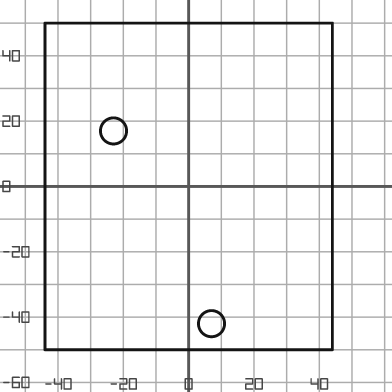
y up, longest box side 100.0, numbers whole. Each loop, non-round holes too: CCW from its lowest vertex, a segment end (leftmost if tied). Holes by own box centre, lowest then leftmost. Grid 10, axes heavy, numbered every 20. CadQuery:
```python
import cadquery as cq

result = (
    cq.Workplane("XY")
    .moveTo(-44.0, -50.0)
    .lineTo(44.0, -50.0)
    .lineTo(44.0, 50.0)
    .lineTo(-44.0, 50.0)
    .close()
    .moveTo(7.0, -42.0)
    .circle(4.0)
    .moveTo(-23.0, 17.0)
    .circle(4.0)
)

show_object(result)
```